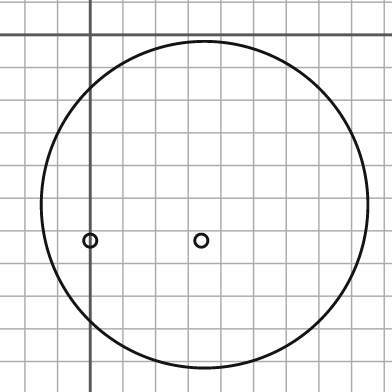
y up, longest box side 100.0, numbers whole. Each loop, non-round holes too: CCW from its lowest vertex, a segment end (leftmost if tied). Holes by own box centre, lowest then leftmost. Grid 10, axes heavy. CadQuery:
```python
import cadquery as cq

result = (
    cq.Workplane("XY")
    .moveTo(35.0, -52.0)
    .circle(50.0)
    .moveTo(0.0, -63.0)
    .circle(2.0)
    .moveTo(34.0, -63.0)
    .circle(2.0)
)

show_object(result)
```